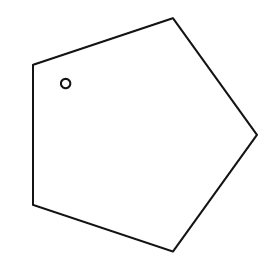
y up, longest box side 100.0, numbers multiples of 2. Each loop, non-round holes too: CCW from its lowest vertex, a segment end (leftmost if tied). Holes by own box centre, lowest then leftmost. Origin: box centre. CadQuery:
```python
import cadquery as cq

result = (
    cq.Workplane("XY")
    .moveTo(12.0, -50.0)
    .lineTo(48.0, 0.0)
    .lineTo(12.0, 50.0)
    .lineTo(-48.0, 30.0)
    .lineTo(-48.0, -30.0)
    .close()
    .moveTo(-34.0, 22.0)
    .circle(2.0)
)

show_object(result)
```